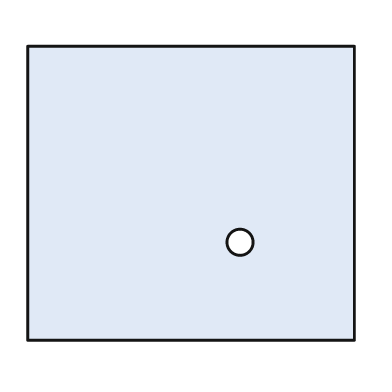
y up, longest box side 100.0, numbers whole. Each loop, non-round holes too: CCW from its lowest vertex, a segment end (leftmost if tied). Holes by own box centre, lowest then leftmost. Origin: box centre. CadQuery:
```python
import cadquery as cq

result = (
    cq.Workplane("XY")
    .moveTo(-50.0, -45.0)
    .lineTo(50.0, -45.0)
    .lineTo(50.0, 45.0)
    .lineTo(-50.0, 45.0)
    .close()
    .moveTo(15.0, -15.0)
    .circle(4.0)
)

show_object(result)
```